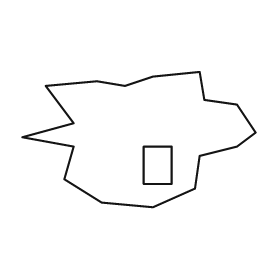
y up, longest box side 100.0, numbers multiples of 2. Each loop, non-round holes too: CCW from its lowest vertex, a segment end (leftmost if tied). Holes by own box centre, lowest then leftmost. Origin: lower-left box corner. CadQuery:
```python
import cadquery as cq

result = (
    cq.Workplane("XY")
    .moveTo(56.0, 0.0)
    .lineTo(74.0, 8.0)
    .lineTo(76.0, 22.0)
    .lineTo(92.0, 26.0)
    .lineTo(100.0, 32.0)
    .lineTo(92.0, 44.0)
    .lineTo(78.0, 46.0)
    .lineTo(76.0, 58.0)
    .lineTo(56.0, 56.0)
    .lineTo(44.0, 52.0)
    .lineTo(32.0, 54.0)
    .lineTo(10.0, 52.0)
    .lineTo(22.0, 36.0)
    .lineTo(0.0, 30.0)
    .lineTo(22.0, 26.0)
    .lineTo(18.0, 12.0)
    .lineTo(34.0, 2.0)
    .close()
    .moveTo(52.0, 10.0)
    .lineTo(64.0, 10.0)
    .lineTo(64.0, 26.0)
    .lineTo(52.0, 26.0)
    .close()
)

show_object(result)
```